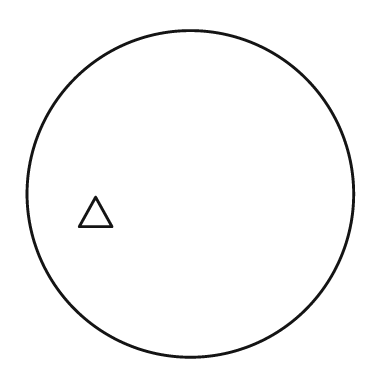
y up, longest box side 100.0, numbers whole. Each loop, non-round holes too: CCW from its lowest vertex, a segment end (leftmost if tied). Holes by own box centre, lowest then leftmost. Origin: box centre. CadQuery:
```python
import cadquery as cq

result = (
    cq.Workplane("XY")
    .moveTo(0.0, 0.0)
    .circle(50.0)
    .moveTo(-34.0, -10.0)
    .lineTo(-24.0, -10.0)
    .lineTo(-29.0, -1.0)
    .close()
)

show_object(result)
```